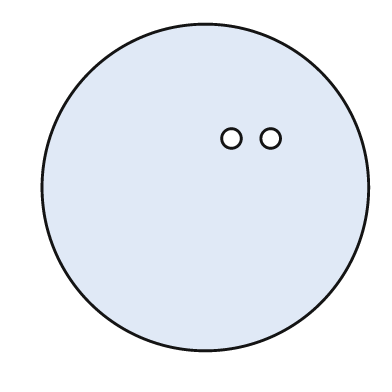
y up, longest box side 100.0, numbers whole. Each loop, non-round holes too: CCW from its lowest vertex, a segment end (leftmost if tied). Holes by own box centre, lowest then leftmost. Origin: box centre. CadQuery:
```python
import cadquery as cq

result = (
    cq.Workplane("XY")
    .moveTo(0.0, 0.0)
    .circle(50.0)
    .moveTo(8.0, 15.0)
    .circle(3.0)
    .moveTo(20.0, 15.0)
    .circle(3.0)
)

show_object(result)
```